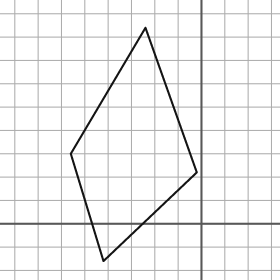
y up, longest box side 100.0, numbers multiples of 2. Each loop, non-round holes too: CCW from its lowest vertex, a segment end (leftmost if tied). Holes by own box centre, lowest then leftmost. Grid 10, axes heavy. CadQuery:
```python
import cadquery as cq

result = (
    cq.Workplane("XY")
    .moveTo(-42.0, -16.0)
    .lineTo(-2.0, 22.0)
    .lineTo(-24.0, 84.0)
    .lineTo(-56.0, 30.0)
    .close()
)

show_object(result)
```